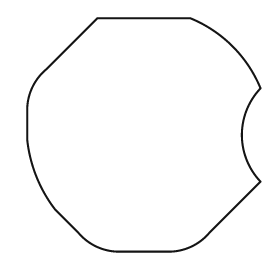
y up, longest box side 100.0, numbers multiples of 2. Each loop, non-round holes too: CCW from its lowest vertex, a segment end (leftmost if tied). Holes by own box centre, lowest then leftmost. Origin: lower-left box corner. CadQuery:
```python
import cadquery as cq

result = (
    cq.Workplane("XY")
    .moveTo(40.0, 0.0)
    .lineTo(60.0, 0.0)
    .threePointArc((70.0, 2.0), (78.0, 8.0))
    .lineTo(100.0, 30.0)
    .threePointArc((92.0, 50.0), (100.0, 70.0))
    .threePointArc((88.0, 88.0), (70.0, 100.0))
    .lineTo(30.0, 100.0)
    .lineTo(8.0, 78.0)
    .threePointArc((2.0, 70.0), (0.0, 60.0))
    .lineTo(0.0, 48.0)
    .threePointArc((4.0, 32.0), (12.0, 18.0))
    .lineTo(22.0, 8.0)
    .threePointArc((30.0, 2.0), (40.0, 0.0))
    .close()
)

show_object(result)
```